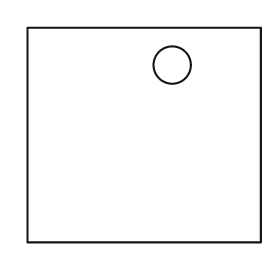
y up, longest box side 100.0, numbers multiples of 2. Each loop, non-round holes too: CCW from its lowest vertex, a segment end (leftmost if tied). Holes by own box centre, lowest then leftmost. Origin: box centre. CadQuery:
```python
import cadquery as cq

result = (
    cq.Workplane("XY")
    .moveTo(-50.0, -46.0)
    .lineTo(50.0, -46.0)
    .lineTo(50.0, 46.0)
    .lineTo(-50.0, 46.0)
    .close()
    .moveTo(12.0, 30.0)
    .circle(8.0)
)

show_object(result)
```